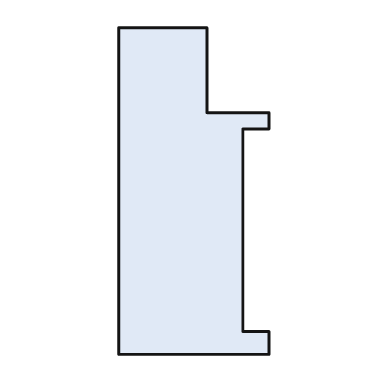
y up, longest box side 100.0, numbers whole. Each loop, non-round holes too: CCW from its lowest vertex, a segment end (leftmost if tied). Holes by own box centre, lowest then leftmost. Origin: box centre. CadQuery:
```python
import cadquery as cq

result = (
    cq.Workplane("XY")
    .moveTo(-23.0, -50.0)
    .lineTo(23.0, -50.0)
    .lineTo(23.0, -43.0)
    .lineTo(15.0, -43.0)
    .lineTo(15.0, 19.0)
    .lineTo(23.0, 19.0)
    .lineTo(23.0, 24.0)
    .lineTo(4.0, 24.0)
    .lineTo(4.0, 50.0)
    .lineTo(-23.0, 50.0)
    .close()
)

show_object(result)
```